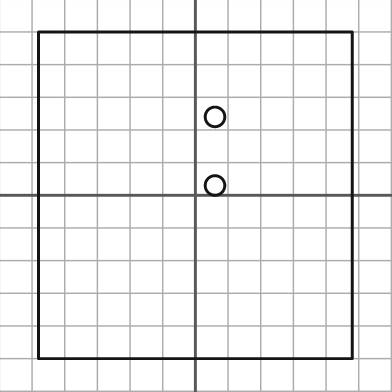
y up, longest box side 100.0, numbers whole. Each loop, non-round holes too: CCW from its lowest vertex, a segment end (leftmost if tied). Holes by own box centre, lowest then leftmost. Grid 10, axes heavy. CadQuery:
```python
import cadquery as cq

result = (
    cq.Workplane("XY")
    .moveTo(-48.0, -50.0)
    .lineTo(48.0, -50.0)
    .lineTo(48.0, 50.0)
    .lineTo(-48.0, 50.0)
    .close()
    .moveTo(6.0, 3.0)
    .circle(3.0)
    .moveTo(6.0, 24.0)
    .circle(3.0)
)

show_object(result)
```